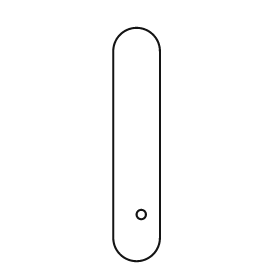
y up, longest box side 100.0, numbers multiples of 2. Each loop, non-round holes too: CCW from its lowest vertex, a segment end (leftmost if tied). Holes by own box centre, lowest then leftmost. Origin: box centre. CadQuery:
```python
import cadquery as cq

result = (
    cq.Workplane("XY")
    .moveTo(-10.0, -40.0)
    .threePointArc((0.0, -50.0), (10.0, -40.0))
    .lineTo(10.0, 40.0)
    .threePointArc((0.0, 50.0), (-10.0, 40.0))
    .close()
    .moveTo(2.0, -30.0)
    .circle(2.0)
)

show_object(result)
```